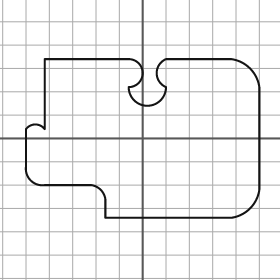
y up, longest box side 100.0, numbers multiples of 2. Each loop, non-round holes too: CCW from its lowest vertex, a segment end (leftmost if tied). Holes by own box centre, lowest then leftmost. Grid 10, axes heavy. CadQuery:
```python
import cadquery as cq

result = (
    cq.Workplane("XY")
    .moveTo(-16.0, -34.0)
    .lineTo(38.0, -34.0)
    .threePointArc((46.0, -30.0), (50.0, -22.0))
    .lineTo(50.0, 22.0)
    .threePointArc((46.0, 30.0), (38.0, 34.0))
    .lineTo(10.0, 34.0)
    .threePointArc((6.0, 28.0), (10.0, 22.0))
    .threePointArc((2.0, 14.0), (-6.0, 22.0))
    .threePointArc((0.0, 28.0), (-6.0, 34.0))
    .lineTo(-42.0, 34.0)
    .lineTo(-42.0, 4.0)
    .threePointArc((-46.0, 6.0), (-50.0, 4.0))
    .lineTo(-50.0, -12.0)
    .threePointArc((-48.0, -18.0), (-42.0, -20.0))
    .lineTo(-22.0, -20.0)
    .threePointArc((-18.0, -22.0), (-16.0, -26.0))
    .close()
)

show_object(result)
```